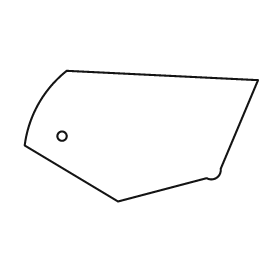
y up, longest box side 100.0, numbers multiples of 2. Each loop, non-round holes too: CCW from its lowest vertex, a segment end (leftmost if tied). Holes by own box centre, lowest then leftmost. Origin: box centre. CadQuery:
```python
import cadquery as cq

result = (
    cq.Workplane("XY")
    .moveTo(-10.0, -28.0)
    .lineTo(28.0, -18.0)
    .threePointArc((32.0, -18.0), (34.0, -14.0))
    .lineTo(50.0, 24.0)
    .lineTo(-32.0, 28.0)
    .threePointArc((-44.0, 14.0), (-50.0, -4.0))
    .close()
    .moveTo(-34.0, 0.0)
    .circle(2.0)
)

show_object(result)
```